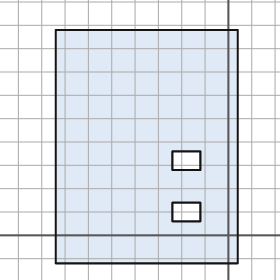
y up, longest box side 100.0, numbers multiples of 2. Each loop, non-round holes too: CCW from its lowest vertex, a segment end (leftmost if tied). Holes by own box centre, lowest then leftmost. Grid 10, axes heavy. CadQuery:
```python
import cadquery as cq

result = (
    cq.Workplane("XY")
    .moveTo(-74.0, -12.0)
    .lineTo(4.0, -12.0)
    .lineTo(4.0, 88.0)
    .lineTo(-74.0, 88.0)
    .close()
    .moveTo(-24.0, 6.0)
    .lineTo(-12.0, 6.0)
    .lineTo(-12.0, 14.0)
    .lineTo(-24.0, 14.0)
    .close()
    .moveTo(-24.0, 28.0)
    .lineTo(-12.0, 28.0)
    .lineTo(-12.0, 36.0)
    .lineTo(-24.0, 36.0)
    .close()
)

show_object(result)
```